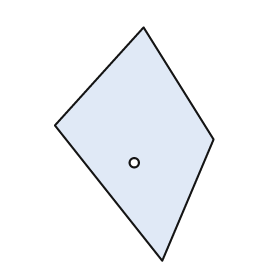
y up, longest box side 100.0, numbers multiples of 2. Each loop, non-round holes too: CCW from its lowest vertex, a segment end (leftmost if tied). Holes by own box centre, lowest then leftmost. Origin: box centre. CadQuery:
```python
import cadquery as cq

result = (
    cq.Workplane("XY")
    .moveTo(12.0, -50.0)
    .lineTo(34.0, 2.0)
    .lineTo(4.0, 50.0)
    .lineTo(-34.0, 8.0)
    .close()
    .moveTo(0.0, -8.0)
    .circle(2.0)
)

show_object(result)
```